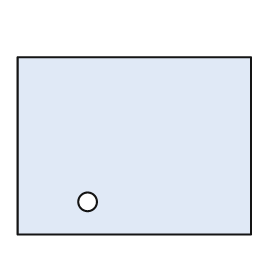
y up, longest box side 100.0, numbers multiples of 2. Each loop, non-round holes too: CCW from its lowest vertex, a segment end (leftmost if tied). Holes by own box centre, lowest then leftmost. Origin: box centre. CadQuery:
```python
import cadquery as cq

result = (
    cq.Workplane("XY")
    .moveTo(-50.0, -38.0)
    .lineTo(50.0, -38.0)
    .lineTo(50.0, 38.0)
    .lineTo(-50.0, 38.0)
    .close()
    .moveTo(-20.0, -24.0)
    .circle(4.0)
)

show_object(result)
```